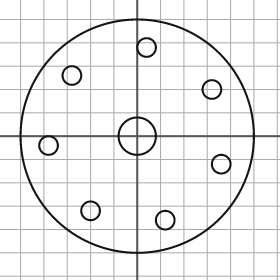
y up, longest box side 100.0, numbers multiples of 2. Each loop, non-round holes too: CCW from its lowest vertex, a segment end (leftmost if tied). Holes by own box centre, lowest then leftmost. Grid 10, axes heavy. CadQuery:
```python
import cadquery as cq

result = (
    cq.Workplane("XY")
    .moveTo(0.0, 0.0)
    .circle(50.0)
    .moveTo(12.0, -36.0)
    .circle(4.0)
    .moveTo(-20.0, -32.0)
    .circle(4.0)
    .moveTo(36.0, -12.0)
    .circle(4.0)
    .moveTo(-38.0, -4.0)
    .circle(4.0)
    .moveTo(0.0, 0.0)
    .circle(8.0)
    .moveTo(32.0, 20.0)
    .circle(4.0)
    .moveTo(-28.0, 26.0)
    .circle(4.0)
    .moveTo(4.0, 38.0)
    .circle(4.0)
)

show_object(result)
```